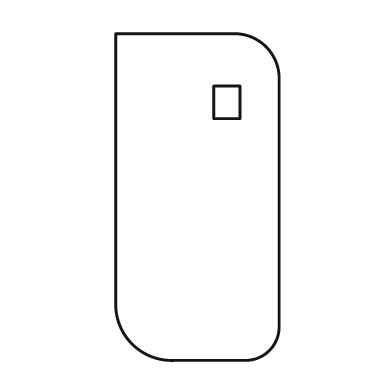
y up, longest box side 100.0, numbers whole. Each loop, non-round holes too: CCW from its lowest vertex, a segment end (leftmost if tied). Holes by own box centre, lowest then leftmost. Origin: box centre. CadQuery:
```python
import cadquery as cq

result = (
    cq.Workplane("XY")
    .moveTo(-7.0, -50.0)
    .lineTo(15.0, -50.0)
    .threePointArc((22.0, -47.0), (25.0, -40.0))
    .lineTo(25.0, 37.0)
    .threePointArc((21.0, 46.0), (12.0, 50.0))
    .lineTo(-25.0, 50.0)
    .lineTo(-25.0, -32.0)
    .threePointArc((-20.0, -45.0), (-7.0, -50.0))
    .close()
    .moveTo(5.0, 24.0)
    .lineTo(13.0, 24.0)
    .lineTo(13.0, 34.0)
    .lineTo(5.0, 34.0)
    .close()
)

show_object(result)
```